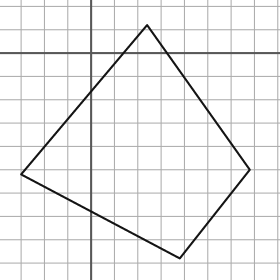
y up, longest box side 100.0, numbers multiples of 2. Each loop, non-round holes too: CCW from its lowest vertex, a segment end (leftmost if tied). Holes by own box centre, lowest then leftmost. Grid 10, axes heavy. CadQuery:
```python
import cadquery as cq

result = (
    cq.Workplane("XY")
    .moveTo(38.0, -88.0)
    .lineTo(68.0, -50.0)
    .lineTo(24.0, 12.0)
    .lineTo(-30.0, -52.0)
    .close()
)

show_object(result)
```